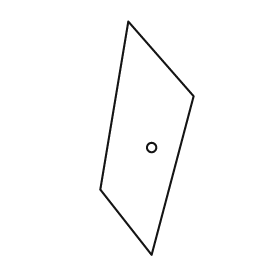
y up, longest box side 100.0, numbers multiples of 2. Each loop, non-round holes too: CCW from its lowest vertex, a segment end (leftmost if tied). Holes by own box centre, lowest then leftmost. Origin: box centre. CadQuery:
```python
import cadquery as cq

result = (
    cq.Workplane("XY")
    .moveTo(2.0, -50.0)
    .lineTo(20.0, 18.0)
    .lineTo(-8.0, 50.0)
    .lineTo(-20.0, -22.0)
    .close()
    .moveTo(2.0, -4.0)
    .circle(2.0)
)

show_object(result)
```